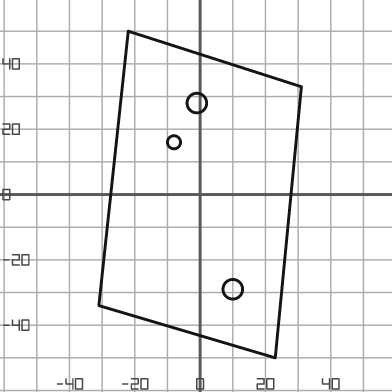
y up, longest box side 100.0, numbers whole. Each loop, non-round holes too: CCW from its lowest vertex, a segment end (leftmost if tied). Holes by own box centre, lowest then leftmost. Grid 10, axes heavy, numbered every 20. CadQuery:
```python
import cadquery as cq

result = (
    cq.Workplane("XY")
    .moveTo(23.0, -50.0)
    .lineTo(31.0, 33.0)
    .lineTo(-22.0, 50.0)
    .lineTo(-31.0, -34.0)
    .close()
    .moveTo(10.0, -29.0)
    .circle(3.0)
    .moveTo(-8.0, 16.0)
    .circle(2.0)
    .moveTo(-1.0, 28.0)
    .circle(3.0)
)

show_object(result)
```